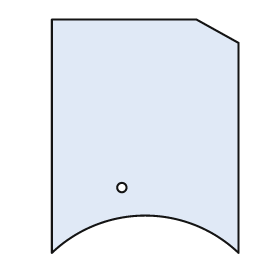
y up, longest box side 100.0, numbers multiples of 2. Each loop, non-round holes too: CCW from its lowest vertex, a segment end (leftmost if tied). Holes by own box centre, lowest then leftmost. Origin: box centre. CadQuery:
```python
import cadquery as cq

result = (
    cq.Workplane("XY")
    .moveTo(-40.0, -50.0)
    .threePointArc((0.0, -34.0), (40.0, -50.0))
    .lineTo(40.0, 40.0)
    .lineTo(22.0, 50.0)
    .lineTo(-40.0, 50.0)
    .close()
    .moveTo(-10.0, -22.0)
    .circle(2.0)
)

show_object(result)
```